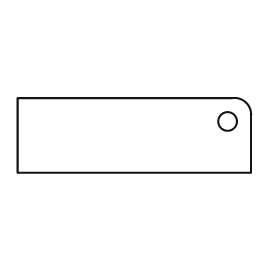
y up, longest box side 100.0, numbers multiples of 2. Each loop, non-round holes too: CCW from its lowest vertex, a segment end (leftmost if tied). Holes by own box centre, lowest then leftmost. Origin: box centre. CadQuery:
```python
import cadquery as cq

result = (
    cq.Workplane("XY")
    .moveTo(-50.0, -16.0)
    .lineTo(50.0, -16.0)
    .lineTo(50.0, 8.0)
    .threePointArc((48.0, 14.0), (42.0, 16.0))
    .lineTo(-50.0, 16.0)
    .close()
    .moveTo(40.0, 6.0)
    .circle(4.0)
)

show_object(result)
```